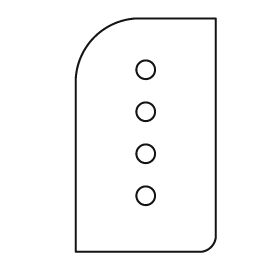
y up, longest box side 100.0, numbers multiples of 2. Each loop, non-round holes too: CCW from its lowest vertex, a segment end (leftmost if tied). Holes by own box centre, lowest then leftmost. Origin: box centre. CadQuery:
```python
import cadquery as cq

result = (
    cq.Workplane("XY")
    .moveTo(-30.0, -50.0)
    .lineTo(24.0, -50.0)
    .threePointArc((28.0, -48.0), (30.0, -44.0))
    .lineTo(30.0, 50.0)
    .lineTo(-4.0, 50.0)
    .threePointArc((-22.0, 42.0), (-30.0, 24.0))
    .close()
    .moveTo(0.0, -26.0)
    .circle(4.0)
    .moveTo(0.0, -8.0)
    .circle(4.0)
    .moveTo(0.0, 10.0)
    .circle(4.0)
    .moveTo(0.0, 28.0)
    .circle(4.0)
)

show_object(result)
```